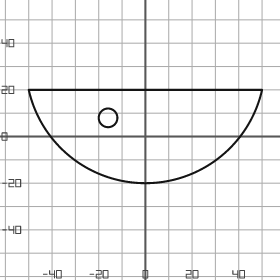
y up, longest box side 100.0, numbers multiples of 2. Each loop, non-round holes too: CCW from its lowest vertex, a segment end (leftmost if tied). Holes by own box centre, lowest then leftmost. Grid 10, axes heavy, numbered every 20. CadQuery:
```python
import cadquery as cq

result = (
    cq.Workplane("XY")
    .moveTo(-50.0, 20.0)
    .threePointArc((0.0, -20.0), (50.0, 20.0))
    .close()
    .moveTo(-16.0, 8.0)
    .circle(4.0)
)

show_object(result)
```